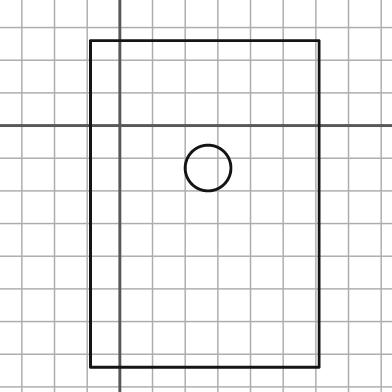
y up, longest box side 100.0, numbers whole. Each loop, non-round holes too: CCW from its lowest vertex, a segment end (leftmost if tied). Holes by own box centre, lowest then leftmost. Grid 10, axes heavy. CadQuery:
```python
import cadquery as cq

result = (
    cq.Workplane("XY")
    .moveTo(-9.0, -74.0)
    .lineTo(61.0, -74.0)
    .lineTo(61.0, 26.0)
    .lineTo(-9.0, 26.0)
    .close()
    .moveTo(27.0, -13.0)
    .circle(7.0)
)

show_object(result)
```